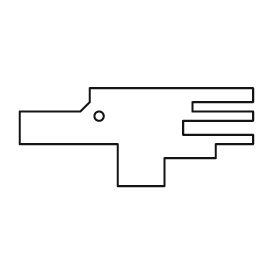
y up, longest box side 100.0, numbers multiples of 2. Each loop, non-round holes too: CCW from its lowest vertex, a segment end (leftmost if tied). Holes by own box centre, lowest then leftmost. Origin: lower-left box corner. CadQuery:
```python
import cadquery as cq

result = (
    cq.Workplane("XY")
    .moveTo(42.0, 0.0)
    .lineTo(62.0, 0.0)
    .lineTo(62.0, 12.0)
    .lineTo(84.0, 12.0)
    .lineTo(84.0, 18.0)
    .lineTo(100.0, 18.0)
    .lineTo(100.0, 22.0)
    .lineTo(70.0, 22.0)
    .lineTo(70.0, 28.0)
    .lineTo(100.0, 28.0)
    .lineTo(100.0, 32.0)
    .lineTo(74.0, 32.0)
    .lineTo(74.0, 36.0)
    .lineTo(100.0, 36.0)
    .lineTo(100.0, 42.0)
    .lineTo(30.0, 42.0)
    .lineTo(30.0, 36.0)
    .lineTo(26.0, 32.0)
    .lineTo(0.0, 32.0)
    .lineTo(0.0, 18.0)
    .lineTo(42.0, 18.0)
    .close()
    .moveTo(34.0, 30.0)
    .circle(2.0)
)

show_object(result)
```